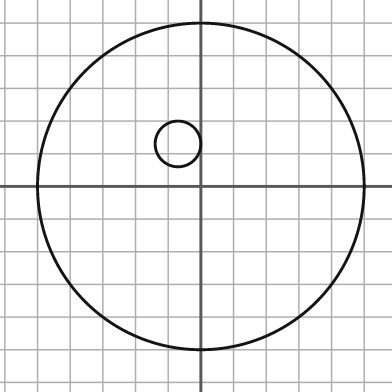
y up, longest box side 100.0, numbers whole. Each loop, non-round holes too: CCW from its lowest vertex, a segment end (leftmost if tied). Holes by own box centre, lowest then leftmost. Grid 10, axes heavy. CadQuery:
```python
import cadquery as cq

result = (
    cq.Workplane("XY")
    .moveTo(0.0, 0.0)
    .circle(50.0)
    .moveTo(-7.0, 13.0)
    .circle(7.0)
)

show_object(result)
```